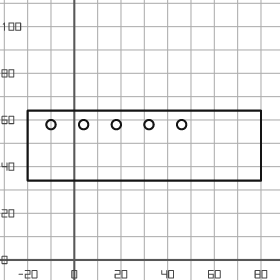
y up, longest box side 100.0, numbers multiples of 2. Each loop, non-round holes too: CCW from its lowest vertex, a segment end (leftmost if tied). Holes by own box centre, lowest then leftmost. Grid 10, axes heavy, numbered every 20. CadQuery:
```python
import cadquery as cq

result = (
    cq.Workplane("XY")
    .moveTo(-20.0, 34.0)
    .lineTo(80.0, 34.0)
    .lineTo(80.0, 64.0)
    .lineTo(-20.0, 64.0)
    .close()
    .moveTo(-10.0, 58.0)
    .circle(2.0)
    .moveTo(4.0, 58.0)
    .circle(2.0)
    .moveTo(18.0, 58.0)
    .circle(2.0)
    .moveTo(32.0, 58.0)
    .circle(2.0)
    .moveTo(46.0, 58.0)
    .circle(2.0)
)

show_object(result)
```